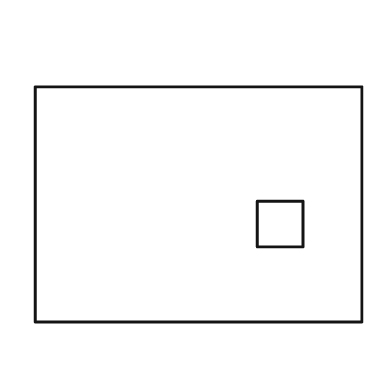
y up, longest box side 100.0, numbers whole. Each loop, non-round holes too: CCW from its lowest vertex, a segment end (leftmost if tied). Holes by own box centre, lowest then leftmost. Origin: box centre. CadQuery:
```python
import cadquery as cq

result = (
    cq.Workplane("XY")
    .moveTo(-50.0, -36.0)
    .lineTo(50.0, -36.0)
    .lineTo(50.0, 36.0)
    .lineTo(-50.0, 36.0)
    .close()
    .moveTo(18.0, -13.0)
    .lineTo(32.0, -13.0)
    .lineTo(32.0, 1.0)
    .lineTo(18.0, 1.0)
    .close()
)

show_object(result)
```